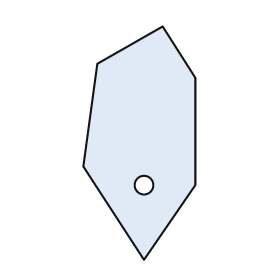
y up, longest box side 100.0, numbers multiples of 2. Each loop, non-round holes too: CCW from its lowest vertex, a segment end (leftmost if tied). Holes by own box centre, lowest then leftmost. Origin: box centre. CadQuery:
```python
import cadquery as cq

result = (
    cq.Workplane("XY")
    .moveTo(2.0, -50.0)
    .lineTo(24.0, -18.0)
    .lineTo(24.0, 28.0)
    .lineTo(10.0, 50.0)
    .lineTo(-18.0, 34.0)
    .lineTo(-24.0, -10.0)
    .close()
    .moveTo(2.0, -18.0)
    .circle(4.0)
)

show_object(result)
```